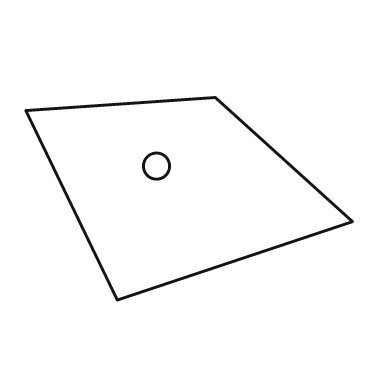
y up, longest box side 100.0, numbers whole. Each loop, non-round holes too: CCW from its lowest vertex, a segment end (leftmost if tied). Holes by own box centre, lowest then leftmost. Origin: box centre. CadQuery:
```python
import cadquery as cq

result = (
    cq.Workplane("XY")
    .moveTo(-22.0, -31.0)
    .lineTo(50.0, -7.0)
    .lineTo(8.0, 31.0)
    .lineTo(-50.0, 27.0)
    .close()
    .moveTo(-10.0, 10.0)
    .circle(4.0)
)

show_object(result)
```